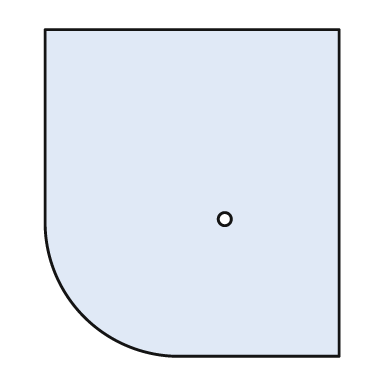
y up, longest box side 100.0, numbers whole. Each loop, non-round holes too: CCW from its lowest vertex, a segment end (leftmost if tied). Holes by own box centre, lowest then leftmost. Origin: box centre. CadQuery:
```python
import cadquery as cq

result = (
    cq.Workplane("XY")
    .moveTo(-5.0, -50.0)
    .lineTo(45.0, -50.0)
    .lineTo(45.0, 50.0)
    .lineTo(-45.0, 50.0)
    .lineTo(-45.0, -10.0)
    .threePointArc((-33.0, -38.0), (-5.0, -50.0))
    .close()
    .moveTo(10.0, -8.0)
    .circle(2.0)
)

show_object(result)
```